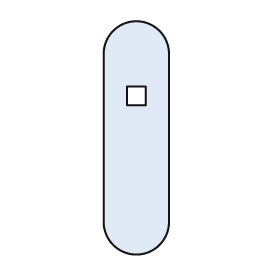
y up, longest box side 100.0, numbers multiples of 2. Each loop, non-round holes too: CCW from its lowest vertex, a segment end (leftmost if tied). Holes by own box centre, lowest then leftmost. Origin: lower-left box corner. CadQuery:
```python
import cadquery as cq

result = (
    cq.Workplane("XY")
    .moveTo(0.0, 14.0)
    .threePointArc((14.0, 0.0), (28.0, 14.0))
    .lineTo(28.0, 86.0)
    .threePointArc((14.0, 100.0), (0.0, 86.0))
    .close()
    .moveTo(10.0, 64.0)
    .lineTo(18.0, 64.0)
    .lineTo(18.0, 72.0)
    .lineTo(10.0, 72.0)
    .close()
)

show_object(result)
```